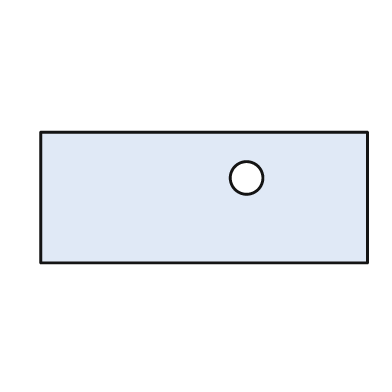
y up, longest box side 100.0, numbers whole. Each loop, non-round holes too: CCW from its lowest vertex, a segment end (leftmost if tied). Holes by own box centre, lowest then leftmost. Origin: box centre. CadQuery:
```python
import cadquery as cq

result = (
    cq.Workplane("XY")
    .moveTo(-50.0, -20.0)
    .lineTo(50.0, -20.0)
    .lineTo(50.0, 20.0)
    .lineTo(-50.0, 20.0)
    .close()
    .moveTo(13.0, 6.0)
    .circle(5.0)
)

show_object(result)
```